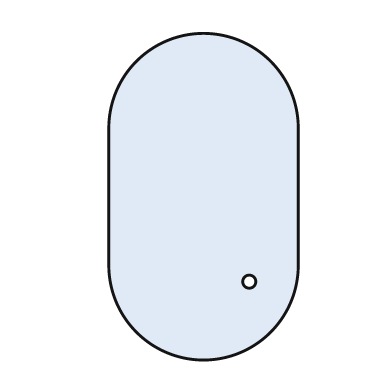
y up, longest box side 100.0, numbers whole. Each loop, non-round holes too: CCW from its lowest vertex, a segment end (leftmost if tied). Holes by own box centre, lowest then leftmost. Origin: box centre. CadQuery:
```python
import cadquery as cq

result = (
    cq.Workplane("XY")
    .moveTo(-29.0, -21.0)
    .threePointArc((0.0, -50.0), (29.0, -21.0))
    .lineTo(29.0, 21.0)
    .threePointArc((0.0, 50.0), (-29.0, 21.0))
    .close()
    .moveTo(14.0, -26.0)
    .circle(2.0)
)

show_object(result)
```